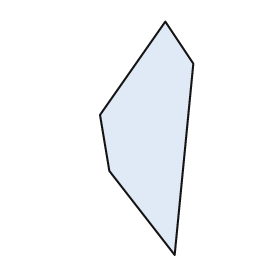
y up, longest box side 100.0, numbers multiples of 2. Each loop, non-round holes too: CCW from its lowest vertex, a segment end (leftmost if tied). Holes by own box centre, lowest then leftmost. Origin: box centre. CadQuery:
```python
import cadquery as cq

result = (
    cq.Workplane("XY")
    .moveTo(12.0, -50.0)
    .lineTo(20.0, 32.0)
    .lineTo(8.0, 50.0)
    .lineTo(-20.0, 10.0)
    .lineTo(-16.0, -14.0)
    .close()
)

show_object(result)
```